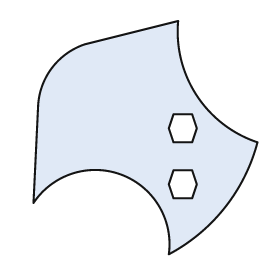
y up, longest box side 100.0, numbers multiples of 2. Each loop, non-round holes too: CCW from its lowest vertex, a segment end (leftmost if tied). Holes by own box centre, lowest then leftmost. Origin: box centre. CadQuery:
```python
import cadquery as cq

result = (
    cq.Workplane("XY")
    .moveTo(10.0, -50.0)
    .threePointArc((34.0, -30.0), (48.0, -2.0))
    .threePointArc((22.0, 18.0), (14.0, 50.0))
    .lineTo(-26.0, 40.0)
    .threePointArc((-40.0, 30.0), (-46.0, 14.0))
    .lineTo(-48.0, -28.0)
    .threePointArc((-10.0, -16.0), (10.0, -50.0))
    .close()
    .moveTo(12.0, -26.0)
    .lineTo(20.0, -26.0)
    .lineTo(22.0, -20.0)
    .lineTo(20.0, -14.0)
    .lineTo(12.0, -14.0)
    .lineTo(10.0, -20.0)
    .close()
    .moveTo(12.0, -2.0)
    .lineTo(20.0, -2.0)
    .lineTo(22.0, 4.0)
    .lineTo(20.0, 10.0)
    .lineTo(12.0, 10.0)
    .lineTo(10.0, 4.0)
    .close()
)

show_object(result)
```